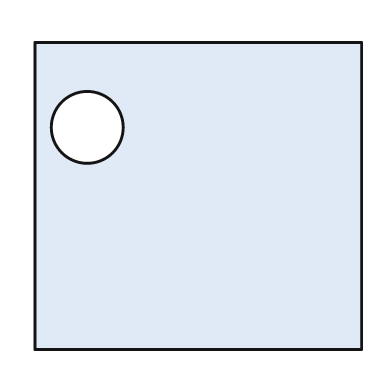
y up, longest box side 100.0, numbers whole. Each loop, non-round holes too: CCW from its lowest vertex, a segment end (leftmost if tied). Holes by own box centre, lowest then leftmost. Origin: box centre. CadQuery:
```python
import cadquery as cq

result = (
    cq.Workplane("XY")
    .moveTo(-50.0, -47.0)
    .lineTo(50.0, -47.0)
    .lineTo(50.0, 47.0)
    .lineTo(-50.0, 47.0)
    .close()
    .moveTo(-34.0, 21.0)
    .circle(11.0)
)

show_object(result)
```